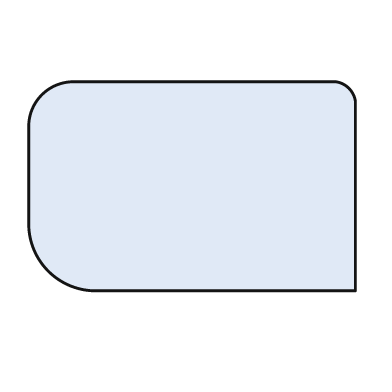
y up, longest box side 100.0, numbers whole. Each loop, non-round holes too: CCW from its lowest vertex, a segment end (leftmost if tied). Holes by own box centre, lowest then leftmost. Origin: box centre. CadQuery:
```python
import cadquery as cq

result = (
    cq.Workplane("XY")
    .moveTo(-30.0, -32.0)
    .lineTo(50.0, -32.0)
    .lineTo(50.0, 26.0)
    .threePointArc((48.0, 30.0), (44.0, 32.0))
    .lineTo(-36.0, 32.0)
    .threePointArc((-46.0, 28.0), (-50.0, 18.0))
    .lineTo(-50.0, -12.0)
    .threePointArc((-44.0, -26.0), (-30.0, -32.0))
    .close()
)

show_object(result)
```